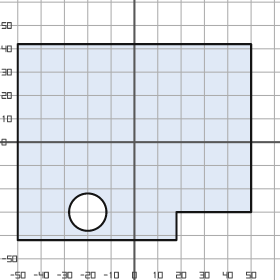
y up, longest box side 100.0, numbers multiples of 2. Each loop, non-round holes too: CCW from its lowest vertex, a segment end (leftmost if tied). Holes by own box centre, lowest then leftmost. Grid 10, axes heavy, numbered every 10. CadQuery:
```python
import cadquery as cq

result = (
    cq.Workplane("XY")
    .moveTo(-50.0, -42.0)
    .lineTo(18.0, -42.0)
    .lineTo(18.0, -30.0)
    .lineTo(50.0, -30.0)
    .lineTo(50.0, 42.0)
    .lineTo(-50.0, 42.0)
    .close()
    .moveTo(-20.0, -30.0)
    .circle(8.0)
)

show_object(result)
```